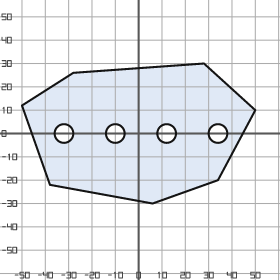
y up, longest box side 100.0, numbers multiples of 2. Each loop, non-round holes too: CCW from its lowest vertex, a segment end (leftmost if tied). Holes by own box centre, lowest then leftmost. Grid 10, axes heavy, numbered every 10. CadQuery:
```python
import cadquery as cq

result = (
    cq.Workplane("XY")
    .moveTo(6.0, -30.0)
    .lineTo(34.0, -20.0)
    .lineTo(50.0, 10.0)
    .lineTo(28.0, 30.0)
    .lineTo(-28.0, 26.0)
    .lineTo(-50.0, 12.0)
    .lineTo(-38.0, -22.0)
    .close()
    .moveTo(-32.0, 0.0)
    .circle(4.0)
    .moveTo(-10.0, 0.0)
    .circle(4.0)
    .moveTo(12.0, 0.0)
    .circle(4.0)
    .moveTo(34.0, 0.0)
    .circle(4.0)
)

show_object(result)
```